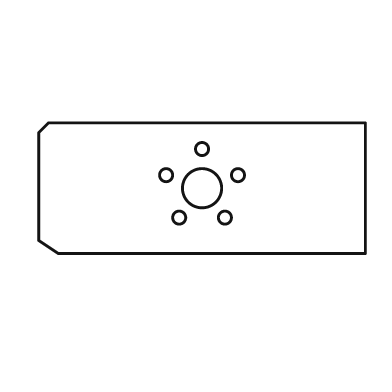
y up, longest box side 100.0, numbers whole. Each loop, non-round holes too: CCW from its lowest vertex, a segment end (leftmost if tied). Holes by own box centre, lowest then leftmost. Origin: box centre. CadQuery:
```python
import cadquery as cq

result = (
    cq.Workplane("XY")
    .moveTo(-44.0, -20.0)
    .lineTo(50.0, -20.0)
    .lineTo(50.0, 20.0)
    .lineTo(-47.0, 20.0)
    .lineTo(-50.0, 17.0)
    .lineTo(-50.0, -16.0)
    .close()
    .moveTo(-7.0, -9.0)
    .circle(2.0)
    .moveTo(7.0, -9.0)
    .circle(2.0)
    .moveTo(0.0, 0.0)
    .circle(6.0)
    .moveTo(-11.0, 4.0)
    .circle(2.0)
    .moveTo(11.0, 4.0)
    .circle(2.0)
    .moveTo(0.0, 12.0)
    .circle(2.0)
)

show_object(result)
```